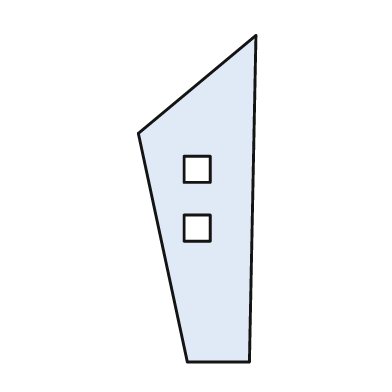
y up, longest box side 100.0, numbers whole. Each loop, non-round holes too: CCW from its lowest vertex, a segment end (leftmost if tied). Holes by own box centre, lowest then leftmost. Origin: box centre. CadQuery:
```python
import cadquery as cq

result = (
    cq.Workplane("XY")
    .moveTo(-3.0, -50.0)
    .lineTo(16.0, -50.0)
    .lineTo(18.0, 50.0)
    .lineTo(-18.0, 20.0)
    .close()
    .moveTo(-4.0, -13.0)
    .lineTo(4.0, -13.0)
    .lineTo(4.0, -5.0)
    .lineTo(-4.0, -5.0)
    .close()
    .moveTo(-4.0, 5.0)
    .lineTo(4.0, 5.0)
    .lineTo(4.0, 13.0)
    .lineTo(-4.0, 13.0)
    .close()
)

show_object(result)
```